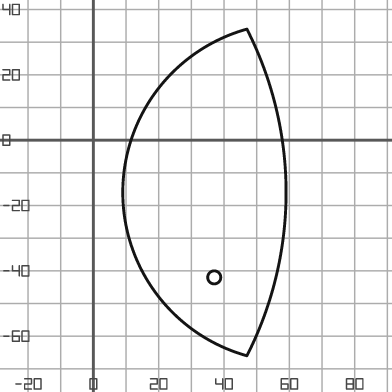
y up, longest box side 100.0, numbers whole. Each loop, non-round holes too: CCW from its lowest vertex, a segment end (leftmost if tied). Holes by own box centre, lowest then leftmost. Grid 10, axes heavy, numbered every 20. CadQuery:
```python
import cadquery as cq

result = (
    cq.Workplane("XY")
    .moveTo(47.0, -66.0)
    .threePointArc((59.0, -16.0), (47.0, 34.0))
    .threePointArc((9.0, -16.0), (47.0, -66.0))
    .close()
    .moveTo(37.0, -42.0)
    .circle(2.0)
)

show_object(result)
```